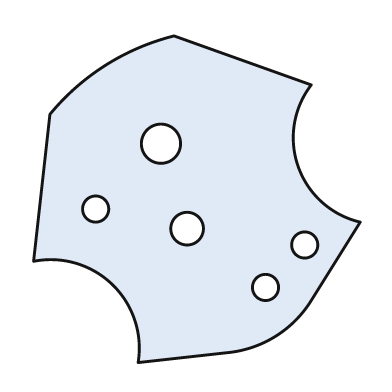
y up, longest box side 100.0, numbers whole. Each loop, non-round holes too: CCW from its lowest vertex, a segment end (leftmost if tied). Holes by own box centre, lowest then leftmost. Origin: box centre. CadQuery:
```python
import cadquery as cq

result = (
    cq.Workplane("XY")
    .moveTo(-18.0, -50.0)
    .lineTo(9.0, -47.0)
    .threePointArc((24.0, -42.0), (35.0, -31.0))
    .lineTo(50.0, -7.0)
    .threePointArc((31.0, 10.0), (35.0, 35.0))
    .lineTo(-7.0, 50.0)
    .threePointArc((-28.0, 41.0), (-45.0, 26.0))
    .lineTo(-50.0, -19.0)
    .threePointArc((-26.0, -26.0), (-18.0, -50.0))
    .close()
    .moveTo(21.0, -27.0)
    .circle(4.0)
    .moveTo(33.0, -14.0)
    .circle(4.0)
    .moveTo(-3.0, -9.0)
    .circle(5.0)
    .moveTo(-31.0, -3.0)
    .circle(4.0)
    .moveTo(-11.0, 17.0)
    .circle(6.0)
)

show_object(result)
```